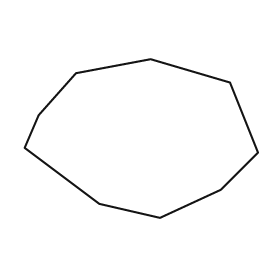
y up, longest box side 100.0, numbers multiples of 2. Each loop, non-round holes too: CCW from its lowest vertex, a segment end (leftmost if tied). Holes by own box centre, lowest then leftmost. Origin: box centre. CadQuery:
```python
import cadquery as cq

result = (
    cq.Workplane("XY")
    .moveTo(8.0, -34.0)
    .lineTo(34.0, -22.0)
    .lineTo(50.0, -6.0)
    .lineTo(38.0, 24.0)
    .lineTo(4.0, 34.0)
    .lineTo(-28.0, 28.0)
    .lineTo(-44.0, 10.0)
    .lineTo(-50.0, -4.0)
    .lineTo(-18.0, -28.0)
    .close()
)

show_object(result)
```